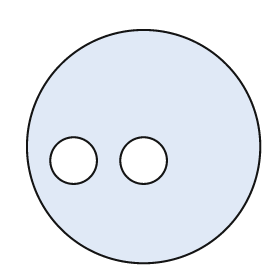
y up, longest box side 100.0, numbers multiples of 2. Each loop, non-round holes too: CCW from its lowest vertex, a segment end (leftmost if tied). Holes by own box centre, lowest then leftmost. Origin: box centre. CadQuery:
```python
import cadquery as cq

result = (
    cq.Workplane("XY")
    .moveTo(0.0, 0.0)
    .circle(50.0)
    .moveTo(-30.0, -6.0)
    .circle(10.0)
    .moveTo(0.0, -6.0)
    .circle(10.0)
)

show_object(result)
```